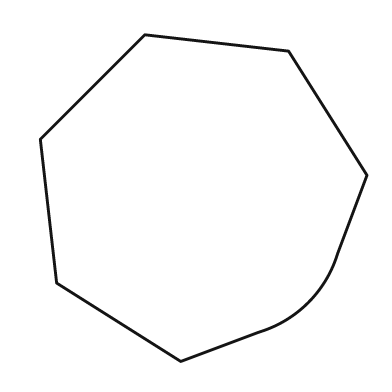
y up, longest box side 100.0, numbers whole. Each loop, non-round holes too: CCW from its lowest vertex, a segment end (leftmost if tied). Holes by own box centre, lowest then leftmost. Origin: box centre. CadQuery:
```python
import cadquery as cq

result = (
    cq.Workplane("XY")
    .moveTo(-7.0, -50.0)
    .lineTo(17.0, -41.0)
    .threePointArc((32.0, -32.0), (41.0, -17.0))
    .lineTo(50.0, 7.0)
    .lineTo(26.0, 45.0)
    .lineTo(-18.0, 50.0)
    .lineTo(-50.0, 18.0)
    .lineTo(-45.0, -26.0)
    .close()
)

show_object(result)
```